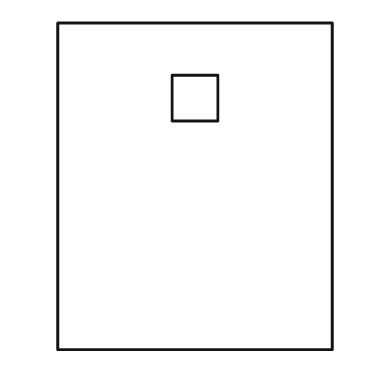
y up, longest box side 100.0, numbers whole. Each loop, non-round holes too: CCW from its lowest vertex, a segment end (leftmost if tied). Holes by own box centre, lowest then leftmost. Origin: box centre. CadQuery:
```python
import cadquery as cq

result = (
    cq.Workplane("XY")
    .moveTo(-42.0, -50.0)
    .lineTo(42.0, -50.0)
    .lineTo(42.0, 50.0)
    .lineTo(-42.0, 50.0)
    .close()
    .moveTo(-7.0, 20.0)
    .lineTo(7.0, 20.0)
    .lineTo(7.0, 34.0)
    .lineTo(-7.0, 34.0)
    .close()
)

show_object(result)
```